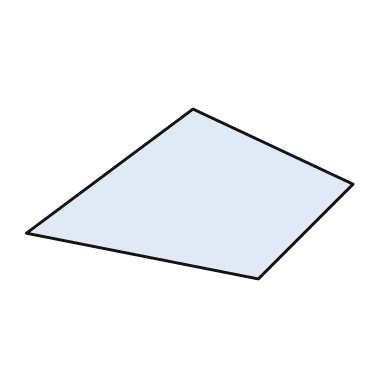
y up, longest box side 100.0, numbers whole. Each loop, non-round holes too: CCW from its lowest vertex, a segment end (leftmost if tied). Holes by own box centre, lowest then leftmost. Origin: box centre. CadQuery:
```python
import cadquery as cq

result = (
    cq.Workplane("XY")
    .moveTo(21.0, -26.0)
    .lineTo(50.0, 3.0)
    .lineTo(1.0, 26.0)
    .lineTo(-50.0, -12.0)
    .close()
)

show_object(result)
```